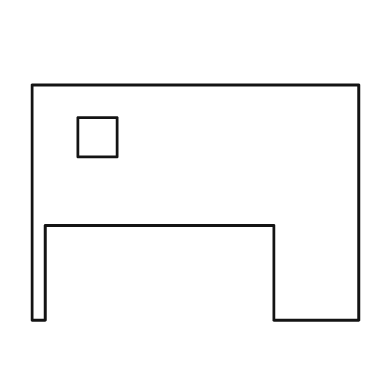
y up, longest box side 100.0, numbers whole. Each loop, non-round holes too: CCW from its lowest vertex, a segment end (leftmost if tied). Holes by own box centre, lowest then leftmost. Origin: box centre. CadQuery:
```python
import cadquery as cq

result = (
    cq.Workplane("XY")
    .moveTo(-50.0, -36.0)
    .lineTo(-46.0, -36.0)
    .lineTo(-46.0, -7.0)
    .lineTo(24.0, -7.0)
    .lineTo(24.0, -36.0)
    .lineTo(50.0, -36.0)
    .lineTo(50.0, 36.0)
    .lineTo(-50.0, 36.0)
    .close()
    .moveTo(-36.0, 14.0)
    .lineTo(-24.0, 14.0)
    .lineTo(-24.0, 26.0)
    .lineTo(-36.0, 26.0)
    .close()
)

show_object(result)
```